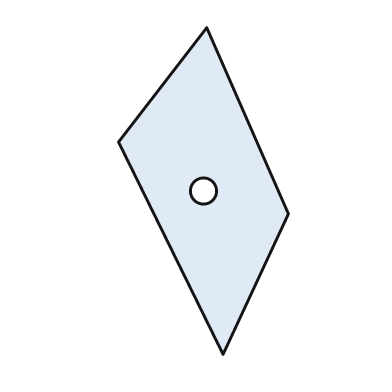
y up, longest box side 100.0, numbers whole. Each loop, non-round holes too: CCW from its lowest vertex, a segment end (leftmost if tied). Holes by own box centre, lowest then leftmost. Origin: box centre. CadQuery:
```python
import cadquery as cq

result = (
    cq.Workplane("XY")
    .moveTo(6.0, -50.0)
    .lineTo(26.0, -7.0)
    .lineTo(1.0, 50.0)
    .lineTo(-26.0, 15.0)
    .close()
    .moveTo(0.0, 0.0)
    .circle(4.0)
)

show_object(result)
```